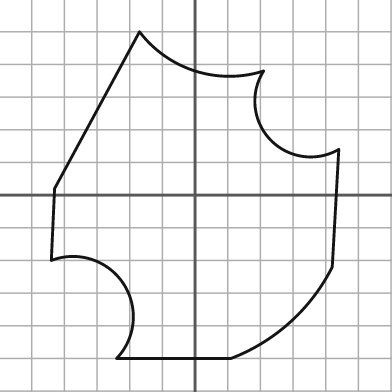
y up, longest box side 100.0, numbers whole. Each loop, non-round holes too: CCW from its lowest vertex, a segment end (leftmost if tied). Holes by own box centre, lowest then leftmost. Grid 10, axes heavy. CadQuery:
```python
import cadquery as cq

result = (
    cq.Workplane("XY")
    .moveTo(-24.0, -50.0)
    .lineTo(11.0, -50.0)
    .threePointArc((29.0, -39.0), (42.0, -22.0))
    .lineTo(44.0, 14.0)
    .threePointArc((23.0, 17.0), (21.0, 38.0))
    .threePointArc((0.0, 38.0), (-17.0, 50.0))
    .lineTo(-43.0, 2.0)
    .lineTo(-44.0, -20.0)
    .threePointArc((-22.0, -27.0), (-24.0, -50.0))
    .close()
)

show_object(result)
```